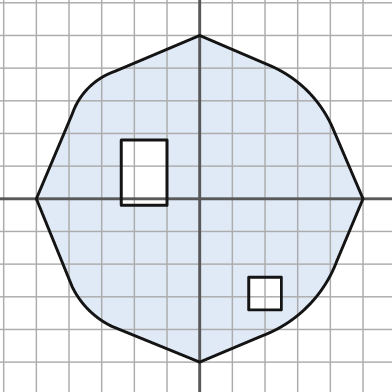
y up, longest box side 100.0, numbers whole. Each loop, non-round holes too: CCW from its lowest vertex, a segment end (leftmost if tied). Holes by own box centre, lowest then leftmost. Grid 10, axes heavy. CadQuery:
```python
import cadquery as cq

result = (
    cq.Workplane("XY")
    .moveTo(0.0, -50.0)
    .lineTo(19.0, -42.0)
    .threePointArc((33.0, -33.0), (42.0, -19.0))
    .lineTo(50.0, 0.0)
    .lineTo(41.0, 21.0)
    .threePointArc((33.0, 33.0), (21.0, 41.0))
    .lineTo(0.0, 50.0)
    .lineTo(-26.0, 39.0)
    .threePointArc((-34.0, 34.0), (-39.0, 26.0))
    .lineTo(-50.0, 0.0)
    .lineTo(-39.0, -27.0)
    .threePointArc((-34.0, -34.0), (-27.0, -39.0))
    .close()
    .moveTo(15.0, -34.0)
    .lineTo(25.0, -34.0)
    .lineTo(25.0, -24.0)
    .lineTo(15.0, -24.0)
    .close()
    .moveTo(-24.0, -2.0)
    .lineTo(-10.0, -2.0)
    .lineTo(-10.0, 18.0)
    .lineTo(-24.0, 18.0)
    .close()
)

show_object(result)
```